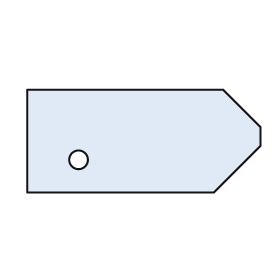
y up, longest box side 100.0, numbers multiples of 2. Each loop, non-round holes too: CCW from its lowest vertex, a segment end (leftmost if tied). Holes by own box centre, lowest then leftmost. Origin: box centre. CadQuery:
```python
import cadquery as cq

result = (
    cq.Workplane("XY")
    .moveTo(-50.0, -22.0)
    .lineTo(30.0, -22.0)
    .lineTo(50.0, -2.0)
    .lineTo(50.0, 6.0)
    .lineTo(34.0, 22.0)
    .lineTo(-50.0, 22.0)
    .close()
    .moveTo(-28.0, -8.0)
    .circle(4.0)
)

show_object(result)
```